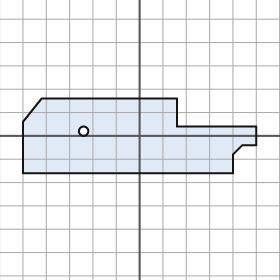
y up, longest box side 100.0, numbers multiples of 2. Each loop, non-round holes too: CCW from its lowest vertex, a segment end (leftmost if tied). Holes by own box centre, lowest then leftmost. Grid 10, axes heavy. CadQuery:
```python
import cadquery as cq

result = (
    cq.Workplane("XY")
    .moveTo(-50.0, -16.0)
    .lineTo(40.0, -16.0)
    .lineTo(40.0, -8.0)
    .lineTo(44.0, -4.0)
    .lineTo(50.0, -4.0)
    .lineTo(50.0, 4.0)
    .lineTo(16.0, 4.0)
    .lineTo(16.0, 16.0)
    .lineTo(-42.0, 16.0)
    .lineTo(-50.0, 6.0)
    .close()
    .moveTo(-24.0, 2.0)
    .circle(2.0)
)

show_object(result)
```